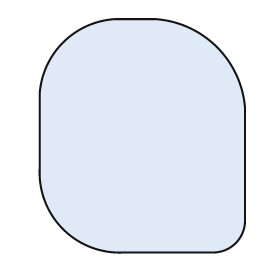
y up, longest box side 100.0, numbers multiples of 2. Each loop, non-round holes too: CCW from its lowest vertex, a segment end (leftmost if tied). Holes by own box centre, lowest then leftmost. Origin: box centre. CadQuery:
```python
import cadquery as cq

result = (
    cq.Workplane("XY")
    .moveTo(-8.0, -50.0)
    .lineTo(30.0, -50.0)
    .threePointArc((40.0, -46.0), (44.0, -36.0))
    .lineTo(44.0, 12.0)
    .threePointArc((32.0, 38.0), (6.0, 50.0))
    .lineTo(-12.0, 50.0)
    .threePointArc((-34.0, 40.0), (-44.0, 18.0))
    .lineTo(-44.0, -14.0)
    .threePointArc((-34.0, -40.0), (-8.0, -50.0))
    .close()
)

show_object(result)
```